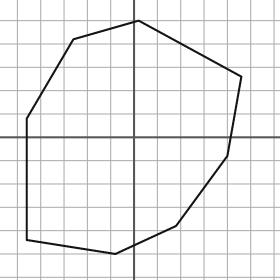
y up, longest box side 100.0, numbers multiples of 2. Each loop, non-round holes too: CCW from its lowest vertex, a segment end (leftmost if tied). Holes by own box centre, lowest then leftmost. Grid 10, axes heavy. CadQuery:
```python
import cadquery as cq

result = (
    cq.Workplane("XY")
    .moveTo(-8.0, -50.0)
    .lineTo(18.0, -38.0)
    .lineTo(40.0, -8.0)
    .lineTo(46.0, 26.0)
    .lineTo(2.0, 50.0)
    .lineTo(-26.0, 42.0)
    .lineTo(-46.0, 8.0)
    .lineTo(-46.0, -44.0)
    .close()
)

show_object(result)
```